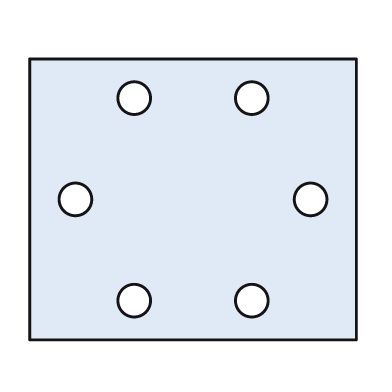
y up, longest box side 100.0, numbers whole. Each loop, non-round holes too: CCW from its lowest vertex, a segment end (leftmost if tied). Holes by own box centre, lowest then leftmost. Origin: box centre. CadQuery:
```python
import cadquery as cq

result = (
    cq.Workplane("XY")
    .moveTo(-50.0, -43.0)
    .lineTo(50.0, -43.0)
    .lineTo(50.0, 43.0)
    .lineTo(-50.0, 43.0)
    .close()
    .moveTo(-18.0, -31.0)
    .circle(5.0)
    .moveTo(18.0, -31.0)
    .circle(5.0)
    .moveTo(-36.0, 0.0)
    .circle(5.0)
    .moveTo(36.0, 0.0)
    .circle(5.0)
    .moveTo(-18.0, 31.0)
    .circle(5.0)
    .moveTo(18.0, 31.0)
    .circle(5.0)
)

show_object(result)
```